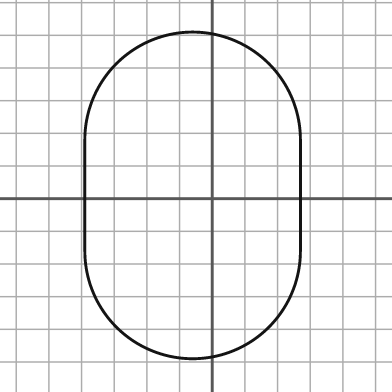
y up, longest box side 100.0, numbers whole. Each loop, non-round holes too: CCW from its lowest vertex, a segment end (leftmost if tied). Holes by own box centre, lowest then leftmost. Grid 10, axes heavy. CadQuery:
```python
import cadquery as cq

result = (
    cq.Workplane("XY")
    .moveTo(-39.0, -16.0)
    .threePointArc((-6.0, -49.0), (27.0, -16.0))
    .lineTo(27.0, 18.0)
    .threePointArc((-6.0, 51.0), (-39.0, 18.0))
    .close()
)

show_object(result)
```